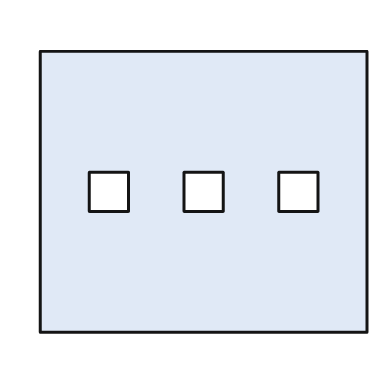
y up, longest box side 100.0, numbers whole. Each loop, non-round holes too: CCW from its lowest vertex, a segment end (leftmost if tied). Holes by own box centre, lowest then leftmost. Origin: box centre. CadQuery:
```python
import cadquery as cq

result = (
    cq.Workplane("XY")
    .moveTo(-50.0, -43.0)
    .lineTo(50.0, -43.0)
    .lineTo(50.0, 43.0)
    .lineTo(-50.0, 43.0)
    .close()
    .moveTo(-35.0, -6.0)
    .lineTo(-23.0, -6.0)
    .lineTo(-23.0, 6.0)
    .lineTo(-35.0, 6.0)
    .close()
    .moveTo(-6.0, -6.0)
    .lineTo(6.0, -6.0)
    .lineTo(6.0, 6.0)
    .lineTo(-6.0, 6.0)
    .close()
    .moveTo(23.0, -6.0)
    .lineTo(35.0, -6.0)
    .lineTo(35.0, 6.0)
    .lineTo(23.0, 6.0)
    .close()
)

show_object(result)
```